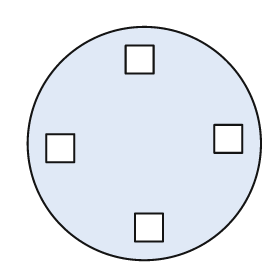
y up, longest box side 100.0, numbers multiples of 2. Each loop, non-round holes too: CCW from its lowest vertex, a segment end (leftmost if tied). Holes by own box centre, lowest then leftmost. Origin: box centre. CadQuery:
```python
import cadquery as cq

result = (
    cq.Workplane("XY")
    .moveTo(0.0, 0.0)
    .circle(50.0)
    .moveTo(-4.0, -42.0)
    .lineTo(8.0, -42.0)
    .lineTo(8.0, -30.0)
    .lineTo(-4.0, -30.0)
    .close()
    .moveTo(-42.0, -8.0)
    .lineTo(-30.0, -8.0)
    .lineTo(-30.0, 4.0)
    .lineTo(-42.0, 4.0)
    .close()
    .moveTo(30.0, -4.0)
    .lineTo(42.0, -4.0)
    .lineTo(42.0, 8.0)
    .lineTo(30.0, 8.0)
    .close()
    .moveTo(-8.0, 30.0)
    .lineTo(4.0, 30.0)
    .lineTo(4.0, 42.0)
    .lineTo(-8.0, 42.0)
    .close()
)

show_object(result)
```